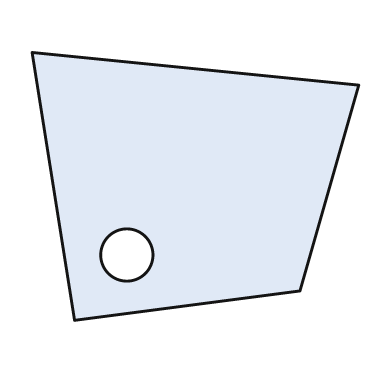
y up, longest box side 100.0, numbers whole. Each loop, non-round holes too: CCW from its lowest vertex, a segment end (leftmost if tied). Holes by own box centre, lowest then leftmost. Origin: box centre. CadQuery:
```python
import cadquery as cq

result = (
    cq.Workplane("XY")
    .moveTo(-37.0, -41.0)
    .lineTo(32.0, -32.0)
    .lineTo(50.0, 31.0)
    .lineTo(-50.0, 41.0)
    .close()
    .moveTo(-21.0, -21.0)
    .circle(8.0)
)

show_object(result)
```